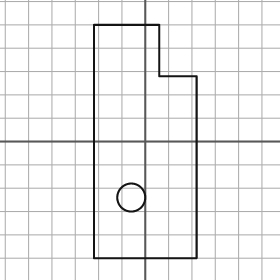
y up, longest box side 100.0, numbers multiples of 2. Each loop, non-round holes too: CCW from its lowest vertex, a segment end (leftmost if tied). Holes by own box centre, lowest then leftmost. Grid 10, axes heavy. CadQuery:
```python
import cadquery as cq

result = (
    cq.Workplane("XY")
    .moveTo(-22.0, -50.0)
    .lineTo(22.0, -50.0)
    .lineTo(22.0, 28.0)
    .lineTo(6.0, 28.0)
    .lineTo(6.0, 50.0)
    .lineTo(-22.0, 50.0)
    .close()
    .moveTo(-6.0, -24.0)
    .circle(6.0)
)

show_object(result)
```